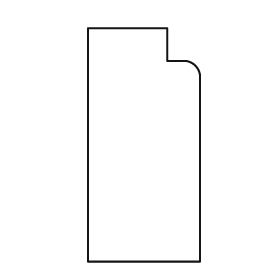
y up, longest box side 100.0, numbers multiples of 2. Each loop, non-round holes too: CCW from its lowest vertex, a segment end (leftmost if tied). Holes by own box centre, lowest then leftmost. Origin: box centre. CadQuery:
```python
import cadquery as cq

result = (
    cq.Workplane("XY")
    .moveTo(-24.0, -50.0)
    .lineTo(24.0, -50.0)
    .lineTo(24.0, 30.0)
    .threePointArc((22.0, 34.0), (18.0, 36.0))
    .lineTo(10.0, 36.0)
    .lineTo(10.0, 50.0)
    .lineTo(-24.0, 50.0)
    .close()
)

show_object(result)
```